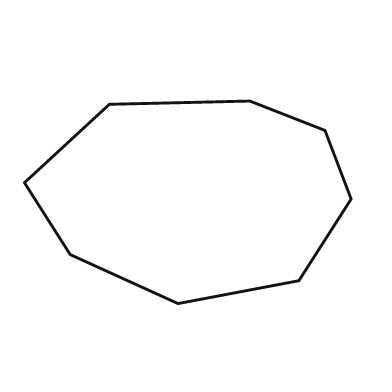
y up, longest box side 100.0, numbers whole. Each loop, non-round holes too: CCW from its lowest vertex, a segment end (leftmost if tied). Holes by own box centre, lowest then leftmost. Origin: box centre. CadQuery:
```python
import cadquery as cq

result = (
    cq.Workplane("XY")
    .moveTo(-3.0, -31.0)
    .lineTo(34.0, -24.0)
    .lineTo(50.0, 1.0)
    .lineTo(42.0, 22.0)
    .lineTo(19.0, 31.0)
    .lineTo(-24.0, 30.0)
    .lineTo(-50.0, 6.0)
    .lineTo(-36.0, -16.0)
    .close()
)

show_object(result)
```